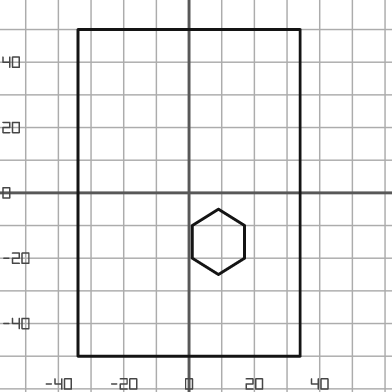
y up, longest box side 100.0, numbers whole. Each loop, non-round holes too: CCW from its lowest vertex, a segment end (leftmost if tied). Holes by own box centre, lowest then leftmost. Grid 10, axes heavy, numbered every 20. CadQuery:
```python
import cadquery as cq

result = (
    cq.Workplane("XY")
    .moveTo(-34.0, -50.0)
    .lineTo(34.0, -50.0)
    .lineTo(34.0, 50.0)
    .lineTo(-34.0, 50.0)
    .close()
    .moveTo(9.0, -25.0)
    .lineTo(17.0, -20.0)
    .lineTo(17.0, -10.0)
    .lineTo(9.0, -5.0)
    .lineTo(1.0, -10.0)
    .lineTo(1.0, -20.0)
    .close()
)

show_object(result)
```